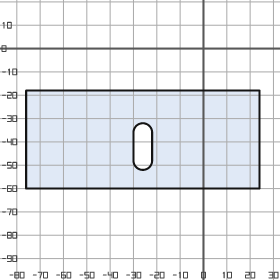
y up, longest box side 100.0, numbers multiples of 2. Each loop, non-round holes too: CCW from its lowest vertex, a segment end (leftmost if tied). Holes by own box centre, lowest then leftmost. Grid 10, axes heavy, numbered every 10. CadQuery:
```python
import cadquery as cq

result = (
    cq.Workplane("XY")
    .moveTo(-76.0, -60.0)
    .lineTo(24.0, -60.0)
    .lineTo(24.0, -18.0)
    .lineTo(-76.0, -18.0)
    .close()
    .moveTo(-30.0, -48.0)
    .threePointArc((-26.0, -52.0), (-22.0, -48.0))
    .lineTo(-22.0, -36.0)
    .threePointArc((-26.0, -32.0), (-30.0, -36.0))
    .close()
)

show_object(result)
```